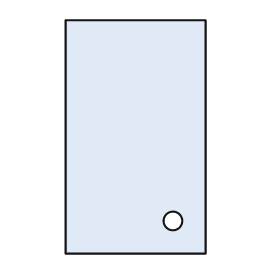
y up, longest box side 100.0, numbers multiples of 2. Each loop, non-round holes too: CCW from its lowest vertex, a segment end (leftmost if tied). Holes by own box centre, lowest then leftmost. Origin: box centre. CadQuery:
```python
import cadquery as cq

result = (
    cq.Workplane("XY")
    .moveTo(-30.0, -50.0)
    .lineTo(30.0, -50.0)
    .lineTo(30.0, 50.0)
    .lineTo(-30.0, 50.0)
    .close()
    .moveTo(16.0, -36.0)
    .circle(4.0)
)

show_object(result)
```